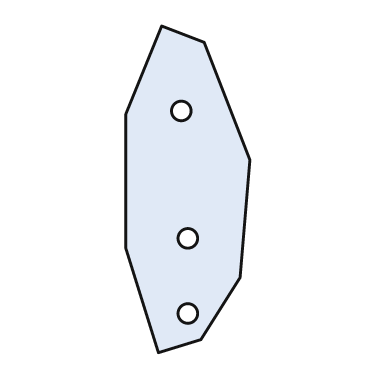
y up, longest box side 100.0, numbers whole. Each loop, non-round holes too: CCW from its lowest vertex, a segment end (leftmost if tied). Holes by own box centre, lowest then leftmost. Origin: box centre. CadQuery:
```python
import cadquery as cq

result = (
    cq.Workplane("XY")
    .moveTo(-9.0, -50.0)
    .lineTo(4.0, -46.0)
    .lineTo(16.0, -27.0)
    .lineTo(19.0, 9.0)
    .lineTo(5.0, 45.0)
    .lineTo(-8.0, 50.0)
    .lineTo(-19.0, 23.0)
    .lineTo(-19.0, -18.0)
    .close()
    .moveTo(0.0, -38.0)
    .circle(3.0)
    .moveTo(0.0, -15.0)
    .circle(3.0)
    .moveTo(-2.0, 24.0)
    .circle(3.0)
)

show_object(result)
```